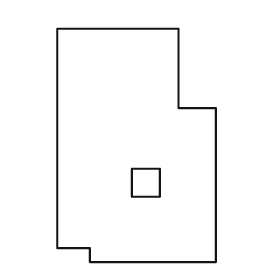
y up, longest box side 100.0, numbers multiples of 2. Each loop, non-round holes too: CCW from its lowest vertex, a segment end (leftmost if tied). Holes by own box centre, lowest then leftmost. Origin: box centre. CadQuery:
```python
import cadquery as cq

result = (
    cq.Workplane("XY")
    .moveTo(-20.0, -50.0)
    .lineTo(34.0, -50.0)
    .lineTo(34.0, 16.0)
    .lineTo(18.0, 16.0)
    .lineTo(18.0, 50.0)
    .lineTo(-34.0, 50.0)
    .lineTo(-34.0, -44.0)
    .lineTo(-20.0, -44.0)
    .close()
    .moveTo(-2.0, -22.0)
    .lineTo(10.0, -22.0)
    .lineTo(10.0, -10.0)
    .lineTo(-2.0, -10.0)
    .close()
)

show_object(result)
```